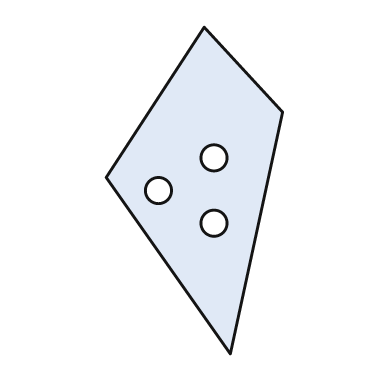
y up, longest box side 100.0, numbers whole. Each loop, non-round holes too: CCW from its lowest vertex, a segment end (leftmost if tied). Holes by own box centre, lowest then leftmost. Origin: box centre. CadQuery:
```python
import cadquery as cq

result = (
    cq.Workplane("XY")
    .moveTo(11.0, -50.0)
    .lineTo(27.0, 24.0)
    .lineTo(3.0, 50.0)
    .lineTo(-27.0, 4.0)
    .close()
    .moveTo(6.0, -10.0)
    .circle(4.0)
    .moveTo(-11.0, 0.0)
    .circle(4.0)
    .moveTo(6.0, 10.0)
    .circle(4.0)
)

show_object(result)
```